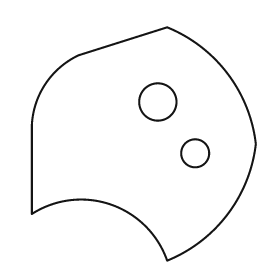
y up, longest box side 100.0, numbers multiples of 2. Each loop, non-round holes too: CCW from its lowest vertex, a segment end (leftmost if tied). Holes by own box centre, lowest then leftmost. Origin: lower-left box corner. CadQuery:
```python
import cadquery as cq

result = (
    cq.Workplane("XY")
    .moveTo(58.0, 0.0)
    .threePointArc((84.0, 20.0), (96.0, 50.0))
    .threePointArc((84.0, 80.0), (58.0, 100.0))
    .lineTo(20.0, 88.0)
    .threePointArc((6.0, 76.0), (0.0, 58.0))
    .lineTo(0.0, 20.0)
    .threePointArc((34.0, 24.0), (58.0, 0.0))
    .close()
    .moveTo(70.0, 46.0)
    .circle(6.0)
    .moveTo(54.0, 68.0)
    .circle(8.0)
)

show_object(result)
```